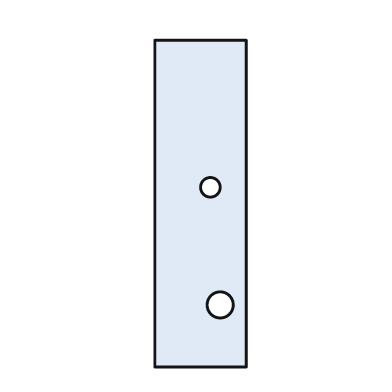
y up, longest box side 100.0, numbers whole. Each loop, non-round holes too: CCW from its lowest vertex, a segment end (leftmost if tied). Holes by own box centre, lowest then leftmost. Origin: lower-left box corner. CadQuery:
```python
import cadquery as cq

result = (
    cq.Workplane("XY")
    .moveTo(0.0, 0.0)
    .lineTo(28.0, 0.0)
    .lineTo(28.0, 100.0)
    .lineTo(0.0, 100.0)
    .close()
    .moveTo(20.0, 19.0)
    .circle(4.0)
    .moveTo(17.0, 55.0)
    .circle(3.0)
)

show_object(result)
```